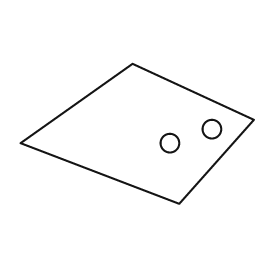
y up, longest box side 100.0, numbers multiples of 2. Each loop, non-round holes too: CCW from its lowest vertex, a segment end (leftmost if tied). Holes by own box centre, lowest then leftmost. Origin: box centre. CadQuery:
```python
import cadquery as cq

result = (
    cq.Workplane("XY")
    .moveTo(18.0, -30.0)
    .lineTo(50.0, 6.0)
    .lineTo(-2.0, 30.0)
    .lineTo(-50.0, -4.0)
    .close()
    .moveTo(14.0, -4.0)
    .circle(4.0)
    .moveTo(32.0, 2.0)
    .circle(4.0)
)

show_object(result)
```